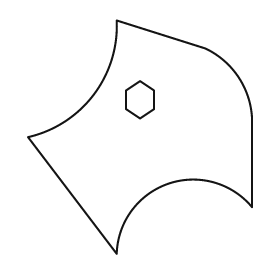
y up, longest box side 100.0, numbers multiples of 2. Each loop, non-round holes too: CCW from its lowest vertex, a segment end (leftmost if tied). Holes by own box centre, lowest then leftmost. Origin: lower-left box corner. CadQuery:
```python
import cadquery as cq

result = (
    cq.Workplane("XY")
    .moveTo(38.0, 0.0)
    .threePointArc((60.0, 30.0), (96.0, 20.0))
    .lineTo(96.0, 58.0)
    .threePointArc((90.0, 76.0), (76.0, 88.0))
    .lineTo(38.0, 100.0)
    .threePointArc((28.0, 68.0), (0.0, 50.0))
    .close()
    .moveTo(48.0, 58.0)
    .lineTo(54.0, 62.0)
    .lineTo(54.0, 70.0)
    .lineTo(48.0, 74.0)
    .lineTo(42.0, 70.0)
    .lineTo(42.0, 62.0)
    .close()
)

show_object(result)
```